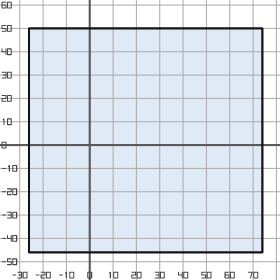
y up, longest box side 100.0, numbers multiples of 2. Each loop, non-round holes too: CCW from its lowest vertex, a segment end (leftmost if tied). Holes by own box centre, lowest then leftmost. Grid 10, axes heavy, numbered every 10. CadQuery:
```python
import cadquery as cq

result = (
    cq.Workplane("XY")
    .moveTo(-26.0, -46.0)
    .lineTo(74.0, -46.0)
    .lineTo(74.0, 50.0)
    .lineTo(-26.0, 50.0)
    .close()
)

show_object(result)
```